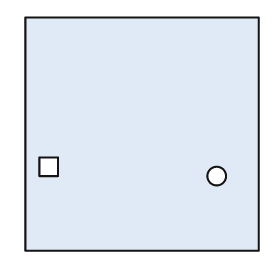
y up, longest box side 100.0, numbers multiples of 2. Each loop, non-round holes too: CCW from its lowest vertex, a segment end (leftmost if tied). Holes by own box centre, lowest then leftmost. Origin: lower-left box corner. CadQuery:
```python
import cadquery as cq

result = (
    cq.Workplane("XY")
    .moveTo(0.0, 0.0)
    .lineTo(100.0, 0.0)
    .lineTo(100.0, 100.0)
    .lineTo(0.0, 100.0)
    .close()
    .moveTo(82.0, 32.0)
    .circle(4.0)
    .moveTo(6.0, 32.0)
    .lineTo(14.0, 32.0)
    .lineTo(14.0, 40.0)
    .lineTo(6.0, 40.0)
    .close()
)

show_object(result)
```